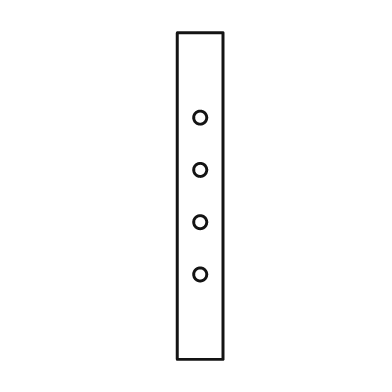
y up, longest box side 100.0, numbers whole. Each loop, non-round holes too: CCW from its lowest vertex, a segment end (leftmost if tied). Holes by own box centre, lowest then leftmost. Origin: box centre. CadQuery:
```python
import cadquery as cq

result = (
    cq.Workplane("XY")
    .moveTo(-7.0, -50.0)
    .lineTo(7.0, -50.0)
    .lineTo(7.0, 50.0)
    .lineTo(-7.0, 50.0)
    .close()
    .moveTo(0.0, -24.0)
    .circle(2.0)
    .moveTo(0.0, -8.0)
    .circle(2.0)
    .moveTo(0.0, 8.0)
    .circle(2.0)
    .moveTo(0.0, 24.0)
    .circle(2.0)
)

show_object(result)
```